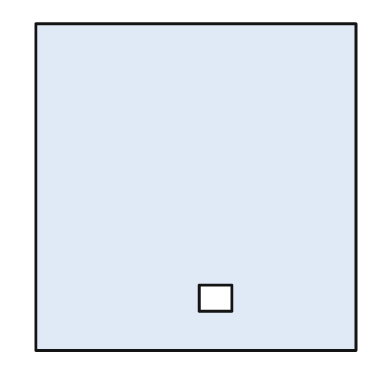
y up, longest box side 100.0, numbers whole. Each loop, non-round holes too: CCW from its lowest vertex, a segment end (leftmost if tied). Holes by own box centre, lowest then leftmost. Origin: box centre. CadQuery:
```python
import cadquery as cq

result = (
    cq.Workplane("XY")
    .moveTo(-49.0, -50.0)
    .lineTo(49.0, -50.0)
    .lineTo(49.0, 50.0)
    .lineTo(-49.0, 50.0)
    .close()
    .moveTo(1.0, -38.0)
    .lineTo(11.0, -38.0)
    .lineTo(11.0, -30.0)
    .lineTo(1.0, -30.0)
    .close()
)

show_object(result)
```